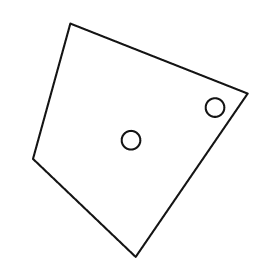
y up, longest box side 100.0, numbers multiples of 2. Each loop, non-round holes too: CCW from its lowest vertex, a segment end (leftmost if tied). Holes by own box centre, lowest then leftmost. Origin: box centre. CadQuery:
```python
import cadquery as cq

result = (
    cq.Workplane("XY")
    .moveTo(-2.0, -50.0)
    .lineTo(46.0, 20.0)
    .lineTo(-30.0, 50.0)
    .lineTo(-46.0, -8.0)
    .close()
    .moveTo(-4.0, 0.0)
    .circle(4.0)
    .moveTo(32.0, 14.0)
    .circle(4.0)
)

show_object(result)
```